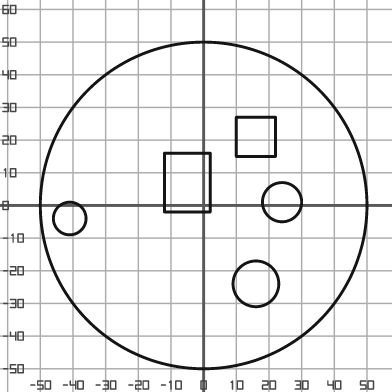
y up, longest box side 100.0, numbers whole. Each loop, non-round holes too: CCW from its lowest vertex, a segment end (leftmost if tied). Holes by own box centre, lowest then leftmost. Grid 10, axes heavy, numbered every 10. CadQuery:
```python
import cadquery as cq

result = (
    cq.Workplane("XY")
    .moveTo(0.0, 0.0)
    .circle(50.0)
    .moveTo(16.0, -24.0)
    .circle(7.0)
    .moveTo(-41.0, -4.0)
    .circle(5.0)
    .moveTo(24.0, 1.0)
    .circle(6.0)
    .moveTo(-12.0, -2.0)
    .lineTo(2.0, -2.0)
    .lineTo(2.0, 16.0)
    .lineTo(-12.0, 16.0)
    .close()
    .moveTo(10.0, 15.0)
    .lineTo(22.0, 15.0)
    .lineTo(22.0, 27.0)
    .lineTo(10.0, 27.0)
    .close()
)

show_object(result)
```